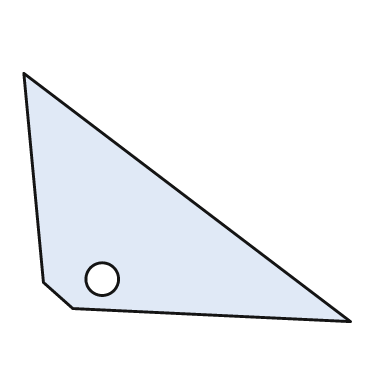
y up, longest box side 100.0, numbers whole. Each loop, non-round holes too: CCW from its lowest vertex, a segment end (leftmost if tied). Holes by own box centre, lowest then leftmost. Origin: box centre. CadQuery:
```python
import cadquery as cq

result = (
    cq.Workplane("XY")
    .moveTo(50.0, -38.0)
    .lineTo(-50.0, 38.0)
    .lineTo(-44.0, -26.0)
    .lineTo(-35.0, -34.0)
    .close()
    .moveTo(-26.0, -25.0)
    .circle(5.0)
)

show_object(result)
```